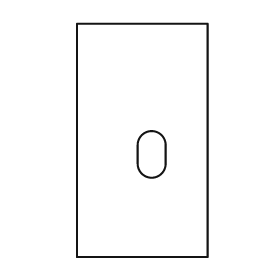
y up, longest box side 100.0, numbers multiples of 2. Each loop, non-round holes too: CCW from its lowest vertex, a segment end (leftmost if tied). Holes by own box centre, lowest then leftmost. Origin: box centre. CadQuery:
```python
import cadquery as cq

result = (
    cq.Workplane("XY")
    .moveTo(-28.0, -50.0)
    .lineTo(28.0, -50.0)
    .lineTo(28.0, 50.0)
    .lineTo(-28.0, 50.0)
    .close()
    .moveTo(-2.0, -10.0)
    .threePointArc((4.0, -16.0), (10.0, -10.0))
    .lineTo(10.0, -2.0)
    .threePointArc((4.0, 4.0), (-2.0, -2.0))
    .close()
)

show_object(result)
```